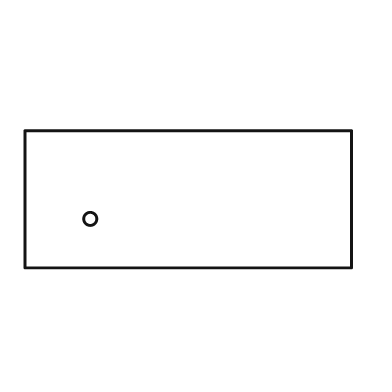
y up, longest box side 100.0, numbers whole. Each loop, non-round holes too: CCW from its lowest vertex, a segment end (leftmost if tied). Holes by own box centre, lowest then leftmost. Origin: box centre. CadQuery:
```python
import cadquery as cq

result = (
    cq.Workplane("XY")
    .moveTo(-50.0, -21.0)
    .lineTo(50.0, -21.0)
    .lineTo(50.0, 21.0)
    .lineTo(-50.0, 21.0)
    .close()
    .moveTo(-30.0, -6.0)
    .circle(2.0)
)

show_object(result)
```